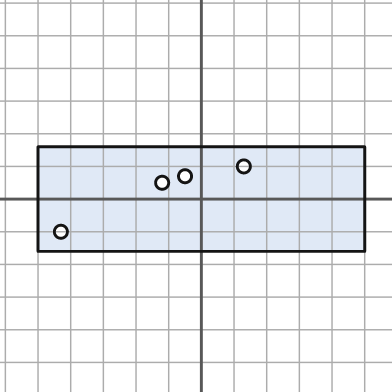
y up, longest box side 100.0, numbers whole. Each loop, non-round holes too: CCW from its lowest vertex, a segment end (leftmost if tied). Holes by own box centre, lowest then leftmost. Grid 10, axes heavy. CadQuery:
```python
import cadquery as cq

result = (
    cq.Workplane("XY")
    .moveTo(-50.0, -16.0)
    .lineTo(50.0, -16.0)
    .lineTo(50.0, 16.0)
    .lineTo(-50.0, 16.0)
    .close()
    .moveTo(-43.0, -10.0)
    .circle(2.0)
    .moveTo(-12.0, 5.0)
    .circle(2.0)
    .moveTo(-5.0, 7.0)
    .circle(2.0)
    .moveTo(13.0, 10.0)
    .circle(2.0)
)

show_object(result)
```